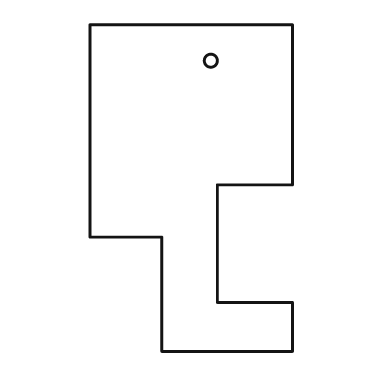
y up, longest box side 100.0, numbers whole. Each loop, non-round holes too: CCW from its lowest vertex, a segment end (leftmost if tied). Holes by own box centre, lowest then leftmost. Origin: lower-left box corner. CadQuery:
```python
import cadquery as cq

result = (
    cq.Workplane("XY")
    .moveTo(22.0, 0.0)
    .lineTo(62.0, 0.0)
    .lineTo(62.0, 15.0)
    .lineTo(39.0, 15.0)
    .lineTo(39.0, 51.0)
    .lineTo(62.0, 51.0)
    .lineTo(62.0, 100.0)
    .lineTo(0.0, 100.0)
    .lineTo(0.0, 35.0)
    .lineTo(22.0, 35.0)
    .close()
    .moveTo(37.0, 89.0)
    .circle(2.0)
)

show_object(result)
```